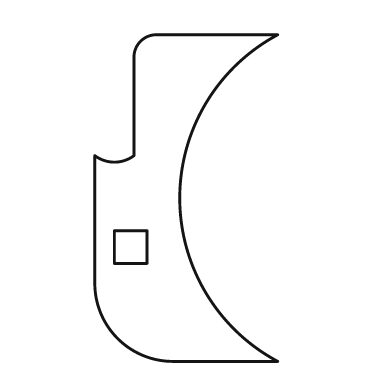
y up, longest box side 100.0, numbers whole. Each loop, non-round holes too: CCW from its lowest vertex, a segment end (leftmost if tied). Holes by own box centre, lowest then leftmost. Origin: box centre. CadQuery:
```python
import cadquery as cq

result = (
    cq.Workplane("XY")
    .moveTo(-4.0, -50.0)
    .lineTo(28.0, -50.0)
    .threePointArc((-2.0, 0.0), (28.0, 50.0))
    .lineTo(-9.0, 50.0)
    .threePointArc((-14.0, 48.0), (-16.0, 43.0))
    .lineTo(-16.0, 13.0)
    .threePointArc((-22.0, 11.0), (-28.0, 13.0))
    .lineTo(-28.0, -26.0)
    .threePointArc((-21.0, -43.0), (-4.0, -50.0))
    .close()
    .moveTo(-22.0, -20.0)
    .lineTo(-12.0, -20.0)
    .lineTo(-12.0, -10.0)
    .lineTo(-22.0, -10.0)
    .close()
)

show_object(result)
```